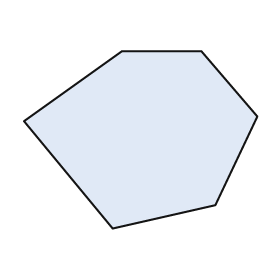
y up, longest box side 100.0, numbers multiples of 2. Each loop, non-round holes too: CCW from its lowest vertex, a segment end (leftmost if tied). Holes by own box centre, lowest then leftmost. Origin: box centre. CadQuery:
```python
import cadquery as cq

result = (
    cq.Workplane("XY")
    .moveTo(-12.0, -38.0)
    .lineTo(32.0, -28.0)
    .lineTo(50.0, 10.0)
    .lineTo(26.0, 38.0)
    .lineTo(-8.0, 38.0)
    .lineTo(-50.0, 8.0)
    .close()
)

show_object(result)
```